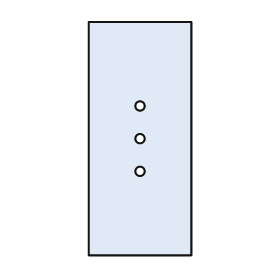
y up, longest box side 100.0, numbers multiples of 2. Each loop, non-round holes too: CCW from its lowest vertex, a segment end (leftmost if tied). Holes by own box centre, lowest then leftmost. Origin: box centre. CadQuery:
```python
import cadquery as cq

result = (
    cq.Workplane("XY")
    .moveTo(-22.0, -50.0)
    .lineTo(22.0, -50.0)
    .lineTo(22.0, 50.0)
    .lineTo(-22.0, 50.0)
    .close()
    .moveTo(0.0, -14.0)
    .circle(2.0)
    .moveTo(0.0, 0.0)
    .circle(2.0)
    .moveTo(0.0, 14.0)
    .circle(2.0)
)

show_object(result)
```